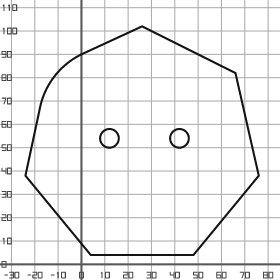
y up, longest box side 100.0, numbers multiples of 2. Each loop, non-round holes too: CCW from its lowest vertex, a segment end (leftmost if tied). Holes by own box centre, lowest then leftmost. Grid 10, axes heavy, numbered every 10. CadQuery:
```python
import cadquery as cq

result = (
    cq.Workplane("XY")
    .moveTo(4.0, 4.0)
    .lineTo(48.0, 4.0)
    .lineTo(76.0, 38.0)
    .lineTo(66.0, 82.0)
    .lineTo(26.0, 102.0)
    .lineTo(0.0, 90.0)
    .threePointArc((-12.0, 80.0), (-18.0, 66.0))
    .lineTo(-24.0, 38.0)
    .close()
    .moveTo(12.0, 54.0)
    .circle(4.0)
    .moveTo(42.0, 54.0)
    .circle(4.0)
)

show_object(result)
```